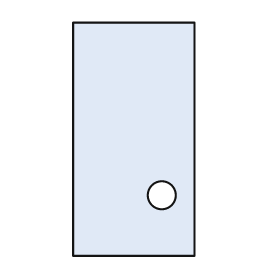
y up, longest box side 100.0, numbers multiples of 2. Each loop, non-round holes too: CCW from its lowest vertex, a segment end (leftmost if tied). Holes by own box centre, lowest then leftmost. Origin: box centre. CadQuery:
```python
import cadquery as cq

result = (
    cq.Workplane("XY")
    .moveTo(-26.0, -50.0)
    .lineTo(26.0, -50.0)
    .lineTo(26.0, 50.0)
    .lineTo(-26.0, 50.0)
    .close()
    .moveTo(12.0, -24.0)
    .circle(6.0)
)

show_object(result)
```